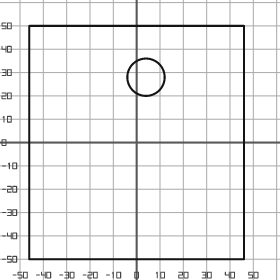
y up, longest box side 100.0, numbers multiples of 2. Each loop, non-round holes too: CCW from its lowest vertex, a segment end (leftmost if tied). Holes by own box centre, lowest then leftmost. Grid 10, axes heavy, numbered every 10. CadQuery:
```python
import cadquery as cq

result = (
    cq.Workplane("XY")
    .moveTo(-46.0, -50.0)
    .lineTo(46.0, -50.0)
    .lineTo(46.0, 50.0)
    .lineTo(-46.0, 50.0)
    .close()
    .moveTo(4.0, 28.0)
    .circle(8.0)
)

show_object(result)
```